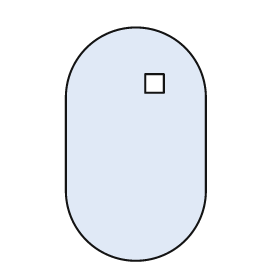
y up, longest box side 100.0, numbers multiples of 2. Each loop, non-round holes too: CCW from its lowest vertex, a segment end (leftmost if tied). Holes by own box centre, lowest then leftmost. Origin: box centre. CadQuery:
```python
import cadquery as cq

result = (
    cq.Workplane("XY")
    .moveTo(-30.0, -20.0)
    .threePointArc((0.0, -50.0), (30.0, -20.0))
    .lineTo(30.0, 20.0)
    .threePointArc((0.0, 50.0), (-30.0, 20.0))
    .close()
    .moveTo(4.0, 22.0)
    .lineTo(12.0, 22.0)
    .lineTo(12.0, 30.0)
    .lineTo(4.0, 30.0)
    .close()
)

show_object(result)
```